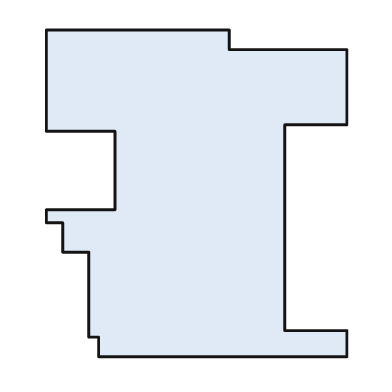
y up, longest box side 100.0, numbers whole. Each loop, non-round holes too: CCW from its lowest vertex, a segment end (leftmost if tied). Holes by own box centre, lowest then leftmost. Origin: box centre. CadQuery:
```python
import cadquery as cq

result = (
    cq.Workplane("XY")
    .moveTo(-30.0, -50.0)
    .lineTo(46.0, -50.0)
    .lineTo(46.0, -42.0)
    .lineTo(27.0, -42.0)
    .lineTo(27.0, 21.0)
    .lineTo(46.0, 21.0)
    .lineTo(46.0, 44.0)
    .lineTo(10.0, 44.0)
    .lineTo(10.0, 50.0)
    .lineTo(-46.0, 50.0)
    .lineTo(-46.0, 19.0)
    .lineTo(-25.0, 19.0)
    .lineTo(-25.0, -5.0)
    .lineTo(-46.0, -5.0)
    .lineTo(-46.0, -9.0)
    .lineTo(-41.0, -9.0)
    .lineTo(-41.0, -18.0)
    .lineTo(-33.0, -18.0)
    .lineTo(-33.0, -44.0)
    .lineTo(-30.0, -44.0)
    .close()
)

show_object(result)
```